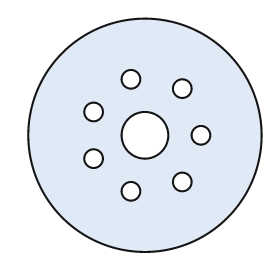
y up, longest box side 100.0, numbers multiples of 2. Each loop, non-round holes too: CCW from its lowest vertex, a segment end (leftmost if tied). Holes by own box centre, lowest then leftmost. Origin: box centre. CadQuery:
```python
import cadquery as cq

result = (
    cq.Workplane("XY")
    .moveTo(0.0, 0.0)
    .circle(50.0)
    .moveTo(-6.0, -24.0)
    .circle(4.0)
    .moveTo(16.0, -20.0)
    .circle(4.0)
    .moveTo(-22.0, -10.0)
    .circle(4.0)
    .moveTo(0.0, 0.0)
    .circle(10.0)
    .moveTo(24.0, 0.0)
    .circle(4.0)
    .moveTo(-22.0, 10.0)
    .circle(4.0)
    .moveTo(16.0, 20.0)
    .circle(4.0)
    .moveTo(-6.0, 24.0)
    .circle(4.0)
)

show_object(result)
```